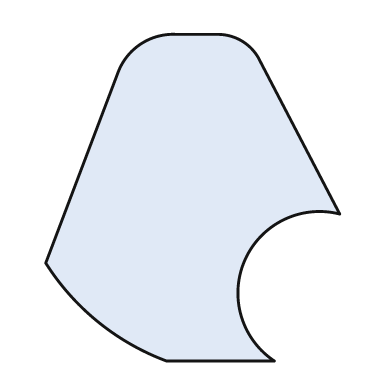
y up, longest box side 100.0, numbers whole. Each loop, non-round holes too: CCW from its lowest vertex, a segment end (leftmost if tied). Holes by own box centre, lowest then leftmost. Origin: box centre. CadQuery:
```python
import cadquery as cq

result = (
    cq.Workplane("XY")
    .moveTo(-8.0, -50.0)
    .lineTo(25.0, -50.0)
    .threePointArc((16.0, -19.0), (45.0, -5.0))
    .lineTo(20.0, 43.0)
    .threePointArc((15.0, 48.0), (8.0, 50.0))
    .lineTo(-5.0, 50.0)
    .threePointArc((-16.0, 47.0), (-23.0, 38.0))
    .lineTo(-45.0, -20.0)
    .threePointArc((-29.0, -38.0), (-8.0, -50.0))
    .close()
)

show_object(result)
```